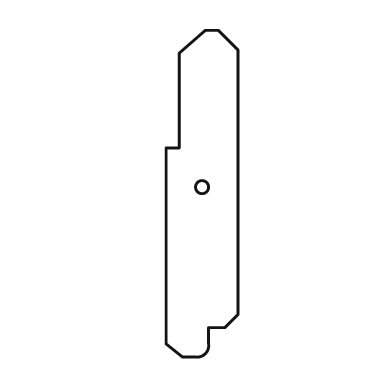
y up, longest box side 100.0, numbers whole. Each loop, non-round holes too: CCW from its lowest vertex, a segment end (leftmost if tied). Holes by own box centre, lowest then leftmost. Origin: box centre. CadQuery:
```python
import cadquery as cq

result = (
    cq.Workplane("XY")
    .moveTo(-6.0, -50.0)
    .lineTo(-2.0, -50.0)
    .threePointArc((1.0, -49.0), (2.0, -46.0))
    .lineTo(2.0, -41.0)
    .lineTo(7.0, -41.0)
    .lineTo(11.0, -37.0)
    .lineTo(11.0, 44.0)
    .lineTo(5.0, 50.0)
    .lineTo(1.0, 50.0)
    .lineTo(-7.0, 43.0)
    .lineTo(-7.0, 14.0)
    .lineTo(-11.0, 14.0)
    .lineTo(-11.0, -46.0)
    .close()
    .moveTo(0.0, 2.0)
    .circle(2.0)
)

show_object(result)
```